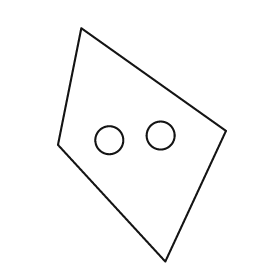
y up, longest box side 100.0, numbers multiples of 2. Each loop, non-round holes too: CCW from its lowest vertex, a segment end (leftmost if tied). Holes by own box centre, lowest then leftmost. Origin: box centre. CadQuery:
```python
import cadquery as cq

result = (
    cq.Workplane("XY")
    .moveTo(10.0, -50.0)
    .lineTo(36.0, 6.0)
    .lineTo(-26.0, 50.0)
    .lineTo(-36.0, 0.0)
    .close()
    .moveTo(-14.0, 2.0)
    .circle(6.0)
    .moveTo(8.0, 4.0)
    .circle(6.0)
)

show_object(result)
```